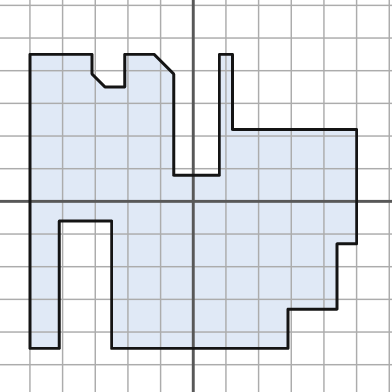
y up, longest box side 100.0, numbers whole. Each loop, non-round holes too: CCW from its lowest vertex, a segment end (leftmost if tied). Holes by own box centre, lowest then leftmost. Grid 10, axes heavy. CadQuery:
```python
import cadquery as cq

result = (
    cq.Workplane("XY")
    .moveTo(-50.0, -45.0)
    .lineTo(-41.0, -45.0)
    .lineTo(-41.0, -6.0)
    .lineTo(-25.0, -6.0)
    .lineTo(-25.0, -45.0)
    .lineTo(29.0, -45.0)
    .lineTo(29.0, -33.0)
    .lineTo(44.0, -33.0)
    .lineTo(44.0, -13.0)
    .lineTo(50.0, -13.0)
    .lineTo(50.0, 22.0)
    .lineTo(12.0, 22.0)
    .lineTo(12.0, 45.0)
    .lineTo(8.0, 45.0)
    .lineTo(8.0, 8.0)
    .lineTo(-6.0, 8.0)
    .lineTo(-6.0, 39.0)
    .lineTo(-12.0, 45.0)
    .lineTo(-21.0, 45.0)
    .lineTo(-21.0, 35.0)
    .lineTo(-27.0, 35.0)
    .lineTo(-31.0, 39.0)
    .lineTo(-31.0, 45.0)
    .lineTo(-50.0, 45.0)
    .close()
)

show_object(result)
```